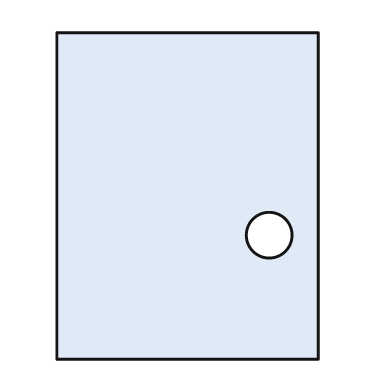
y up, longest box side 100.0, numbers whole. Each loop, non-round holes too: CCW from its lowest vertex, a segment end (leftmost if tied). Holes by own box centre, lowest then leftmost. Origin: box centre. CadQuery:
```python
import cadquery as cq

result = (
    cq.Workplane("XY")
    .moveTo(-40.0, -50.0)
    .lineTo(40.0, -50.0)
    .lineTo(40.0, 50.0)
    .lineTo(-40.0, 50.0)
    .close()
    .moveTo(25.0, -12.0)
    .circle(7.0)
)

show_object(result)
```